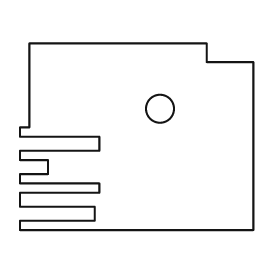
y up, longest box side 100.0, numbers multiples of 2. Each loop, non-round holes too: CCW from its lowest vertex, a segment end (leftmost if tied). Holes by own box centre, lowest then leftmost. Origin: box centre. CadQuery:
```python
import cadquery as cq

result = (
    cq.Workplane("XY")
    .moveTo(-50.0, -40.0)
    .lineTo(50.0, -40.0)
    .lineTo(50.0, 32.0)
    .lineTo(30.0, 32.0)
    .lineTo(30.0, 40.0)
    .lineTo(-46.0, 40.0)
    .lineTo(-46.0, 4.0)
    .lineTo(-50.0, 4.0)
    .lineTo(-50.0, 0.0)
    .lineTo(-16.0, 0.0)
    .lineTo(-16.0, -6.0)
    .lineTo(-50.0, -6.0)
    .lineTo(-50.0, -10.0)
    .lineTo(-38.0, -10.0)
    .lineTo(-38.0, -16.0)
    .lineTo(-50.0, -16.0)
    .lineTo(-50.0, -20.0)
    .lineTo(-16.0, -20.0)
    .lineTo(-16.0, -24.0)
    .lineTo(-50.0, -24.0)
    .lineTo(-50.0, -30.0)
    .lineTo(-18.0, -30.0)
    .lineTo(-18.0, -36.0)
    .lineTo(-50.0, -36.0)
    .close()
    .moveTo(10.0, 12.0)
    .circle(6.0)
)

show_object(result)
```